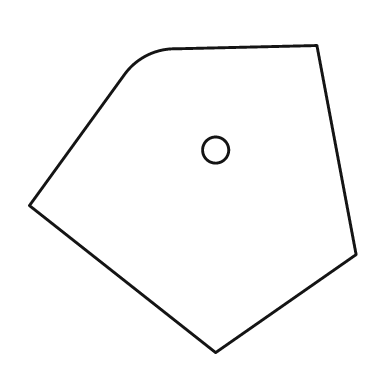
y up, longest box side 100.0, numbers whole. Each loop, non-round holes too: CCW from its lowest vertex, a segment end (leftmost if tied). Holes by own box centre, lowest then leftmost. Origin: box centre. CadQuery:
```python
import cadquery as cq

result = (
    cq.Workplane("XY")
    .moveTo(7.0, -47.0)
    .lineTo(50.0, -17.0)
    .lineTo(38.0, 47.0)
    .lineTo(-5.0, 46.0)
    .threePointArc((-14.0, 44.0), (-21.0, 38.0))
    .lineTo(-50.0, -2.0)
    .close()
    .moveTo(7.0, 15.0)
    .circle(4.0)
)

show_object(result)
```